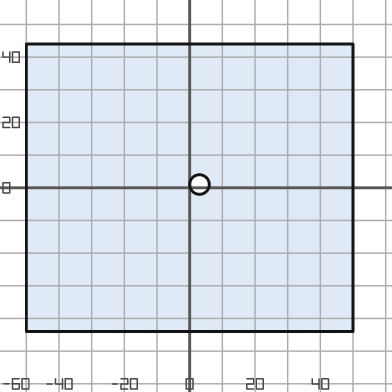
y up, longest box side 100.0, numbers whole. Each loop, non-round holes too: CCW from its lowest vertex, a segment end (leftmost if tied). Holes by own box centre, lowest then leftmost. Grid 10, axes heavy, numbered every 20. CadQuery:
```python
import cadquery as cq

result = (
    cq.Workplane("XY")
    .moveTo(-50.0, -44.0)
    .lineTo(50.0, -44.0)
    .lineTo(50.0, 44.0)
    .lineTo(-50.0, 44.0)
    .close()
    .moveTo(3.0, 1.0)
    .circle(3.0)
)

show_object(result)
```